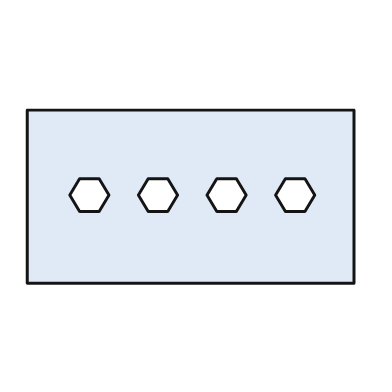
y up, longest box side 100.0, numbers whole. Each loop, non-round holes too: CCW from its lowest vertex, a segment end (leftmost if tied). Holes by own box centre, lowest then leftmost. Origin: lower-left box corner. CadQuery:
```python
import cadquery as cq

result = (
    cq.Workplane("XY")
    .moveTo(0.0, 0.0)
    .lineTo(100.0, 0.0)
    .lineTo(100.0, 53.0)
    .lineTo(0.0, 53.0)
    .close()
    .moveTo(16.0, 22.0)
    .lineTo(22.0, 22.0)
    .lineTo(25.0, 27.0)
    .lineTo(22.0, 32.0)
    .lineTo(16.0, 32.0)
    .lineTo(13.0, 27.0)
    .close()
    .moveTo(37.0, 22.0)
    .lineTo(43.0, 22.0)
    .lineTo(46.0, 27.0)
    .lineTo(43.0, 32.0)
    .lineTo(37.0, 32.0)
    .lineTo(34.0, 27.0)
    .close()
    .moveTo(58.0, 22.0)
    .lineTo(64.0, 22.0)
    .lineTo(67.0, 27.0)
    .lineTo(64.0, 32.0)
    .lineTo(58.0, 32.0)
    .lineTo(55.0, 27.0)
    .close()
    .moveTo(79.0, 22.0)
    .lineTo(85.0, 22.0)
    .lineTo(88.0, 27.0)
    .lineTo(85.0, 32.0)
    .lineTo(79.0, 32.0)
    .lineTo(76.0, 27.0)
    .close()
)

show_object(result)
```